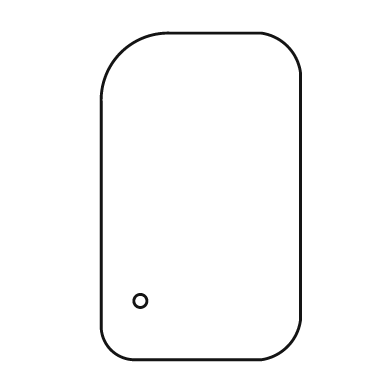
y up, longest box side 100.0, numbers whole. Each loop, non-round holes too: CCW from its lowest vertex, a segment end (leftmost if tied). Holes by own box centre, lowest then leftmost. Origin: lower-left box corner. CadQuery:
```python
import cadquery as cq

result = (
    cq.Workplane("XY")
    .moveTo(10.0, 0.0)
    .lineTo(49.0, 0.0)
    .threePointArc((57.0, 4.0), (61.0, 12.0))
    .lineTo(61.0, 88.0)
    .threePointArc((57.0, 96.0), (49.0, 100.0))
    .lineTo(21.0, 100.0)
    .threePointArc((6.0, 94.0), (0.0, 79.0))
    .lineTo(0.0, 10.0)
    .threePointArc((3.0, 3.0), (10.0, 0.0))
    .close()
    .moveTo(12.0, 18.0)
    .circle(2.0)
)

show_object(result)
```